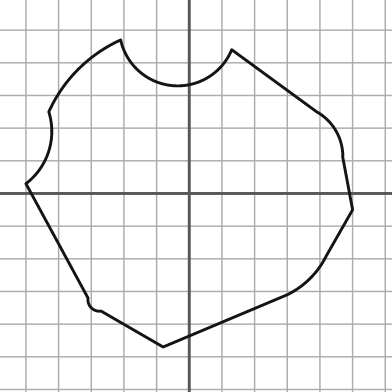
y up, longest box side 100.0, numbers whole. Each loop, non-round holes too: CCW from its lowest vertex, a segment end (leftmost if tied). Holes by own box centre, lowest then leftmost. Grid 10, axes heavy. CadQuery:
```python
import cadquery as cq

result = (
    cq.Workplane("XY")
    .moveTo(-8.0, -47.0)
    .lineTo(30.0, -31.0)
    .threePointArc((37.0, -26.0), (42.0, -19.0))
    .lineTo(50.0, -5.0)
    .lineTo(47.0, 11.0)
    .threePointArc((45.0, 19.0), (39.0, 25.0))
    .lineTo(13.0, 44.0)
    .threePointArc((-5.0, 33.0), (-21.0, 47.0))
    .threePointArc((-34.0, 38.0), (-43.0, 25.0))
    .threePointArc((-43.0, 13.0), (-50.0, 3.0))
    .lineTo(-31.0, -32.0)
    .threePointArc((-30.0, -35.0), (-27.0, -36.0))
    .close()
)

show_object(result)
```